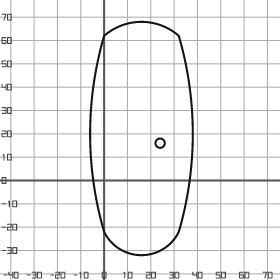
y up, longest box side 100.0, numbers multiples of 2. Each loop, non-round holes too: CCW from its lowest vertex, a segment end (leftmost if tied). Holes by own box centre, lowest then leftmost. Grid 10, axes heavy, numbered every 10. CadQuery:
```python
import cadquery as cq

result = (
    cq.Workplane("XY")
    .moveTo(0.0, -22.0)
    .threePointArc((16.0, -32.0), (32.0, -22.0))
    .threePointArc((38.0, 20.0), (32.0, 62.0))
    .threePointArc((16.0, 68.0), (0.0, 62.0))
    .threePointArc((-6.0, 20.0), (0.0, -22.0))
    .close()
    .moveTo(24.0, 16.0)
    .circle(2.0)
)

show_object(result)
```